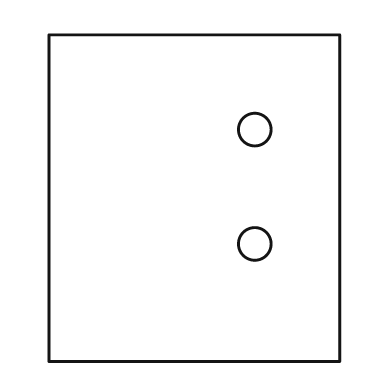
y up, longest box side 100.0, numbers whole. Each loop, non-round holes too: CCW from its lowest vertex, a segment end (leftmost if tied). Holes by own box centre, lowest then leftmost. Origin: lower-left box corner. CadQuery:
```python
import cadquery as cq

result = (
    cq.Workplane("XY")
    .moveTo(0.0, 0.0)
    .lineTo(89.0, 0.0)
    .lineTo(89.0, 100.0)
    .lineTo(0.0, 100.0)
    .close()
    .moveTo(63.0, 36.0)
    .circle(5.0)
    .moveTo(63.0, 71.0)
    .circle(5.0)
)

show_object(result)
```